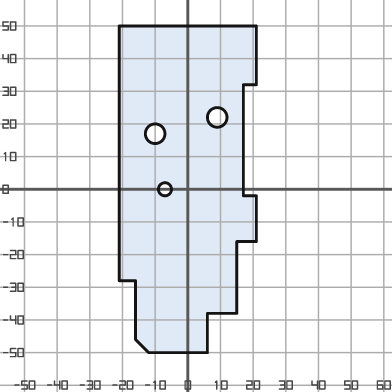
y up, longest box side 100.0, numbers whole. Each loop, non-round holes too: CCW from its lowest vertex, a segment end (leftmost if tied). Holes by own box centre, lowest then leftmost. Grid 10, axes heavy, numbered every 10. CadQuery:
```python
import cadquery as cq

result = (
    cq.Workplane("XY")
    .moveTo(-12.0, -50.0)
    .lineTo(6.0, -50.0)
    .lineTo(6.0, -38.0)
    .lineTo(15.0, -38.0)
    .lineTo(15.0, -16.0)
    .lineTo(21.0, -16.0)
    .lineTo(21.0, -2.0)
    .lineTo(17.0, -2.0)
    .lineTo(17.0, 32.0)
    .lineTo(21.0, 32.0)
    .lineTo(21.0, 50.0)
    .lineTo(-21.0, 50.0)
    .lineTo(-21.0, -28.0)
    .lineTo(-16.0, -28.0)
    .lineTo(-16.0, -46.0)
    .close()
    .moveTo(-7.0, 0.0)
    .circle(2.0)
    .moveTo(-10.0, 17.0)
    .circle(3.0)
    .moveTo(9.0, 22.0)
    .circle(3.0)
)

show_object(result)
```